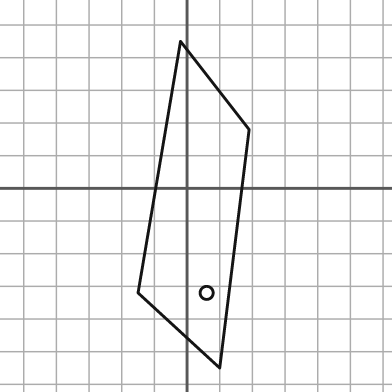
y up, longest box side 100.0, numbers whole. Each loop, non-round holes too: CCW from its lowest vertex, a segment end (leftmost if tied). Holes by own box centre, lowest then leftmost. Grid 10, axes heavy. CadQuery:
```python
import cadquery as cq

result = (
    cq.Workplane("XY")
    .moveTo(10.0, -55.0)
    .lineTo(19.0, 18.0)
    .lineTo(-2.0, 45.0)
    .lineTo(-15.0, -32.0)
    .close()
    .moveTo(6.0, -32.0)
    .circle(2.0)
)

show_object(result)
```